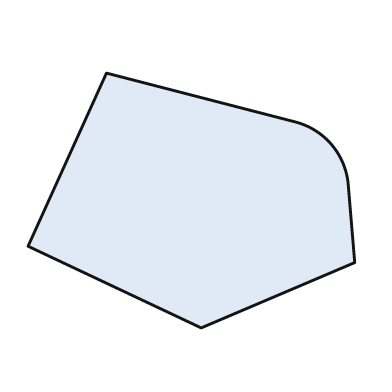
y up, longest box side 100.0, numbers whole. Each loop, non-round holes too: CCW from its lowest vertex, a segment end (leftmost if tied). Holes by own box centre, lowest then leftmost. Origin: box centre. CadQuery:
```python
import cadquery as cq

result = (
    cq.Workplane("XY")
    .moveTo(3.0, -39.0)
    .lineTo(50.0, -19.0)
    .lineTo(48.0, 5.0)
    .threePointArc((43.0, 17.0), (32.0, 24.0))
    .lineTo(-26.0, 39.0)
    .lineTo(-50.0, -14.0)
    .close()
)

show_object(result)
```